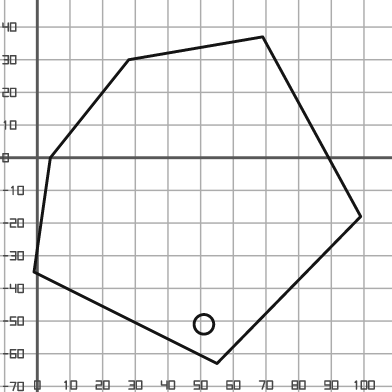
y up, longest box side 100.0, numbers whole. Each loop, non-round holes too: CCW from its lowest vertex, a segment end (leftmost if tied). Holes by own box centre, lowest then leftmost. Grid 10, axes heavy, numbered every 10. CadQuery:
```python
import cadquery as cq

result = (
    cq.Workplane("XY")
    .moveTo(55.0, -63.0)
    .lineTo(99.0, -18.0)
    .lineTo(69.0, 37.0)
    .lineTo(28.0, 30.0)
    .lineTo(4.0, 0.0)
    .lineTo(-1.0, -35.0)
    .close()
    .moveTo(51.0, -51.0)
    .circle(3.0)
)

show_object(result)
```